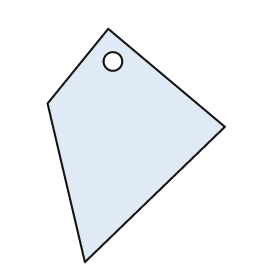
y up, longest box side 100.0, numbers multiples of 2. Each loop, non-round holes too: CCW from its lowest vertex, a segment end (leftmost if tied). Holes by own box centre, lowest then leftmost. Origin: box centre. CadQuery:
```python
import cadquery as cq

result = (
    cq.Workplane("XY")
    .moveTo(-22.0, -50.0)
    .lineTo(38.0, 8.0)
    .lineTo(-12.0, 50.0)
    .lineTo(-38.0, 18.0)
    .close()
    .moveTo(-10.0, 36.0)
    .circle(4.0)
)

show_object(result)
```